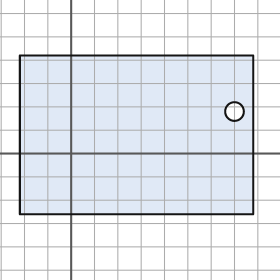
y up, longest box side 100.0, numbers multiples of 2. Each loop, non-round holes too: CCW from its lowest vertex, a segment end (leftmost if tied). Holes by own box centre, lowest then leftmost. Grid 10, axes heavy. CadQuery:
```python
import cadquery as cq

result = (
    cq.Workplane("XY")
    .moveTo(-22.0, -26.0)
    .lineTo(78.0, -26.0)
    .lineTo(78.0, 42.0)
    .lineTo(-22.0, 42.0)
    .close()
    .moveTo(70.0, 18.0)
    .circle(4.0)
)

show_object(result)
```